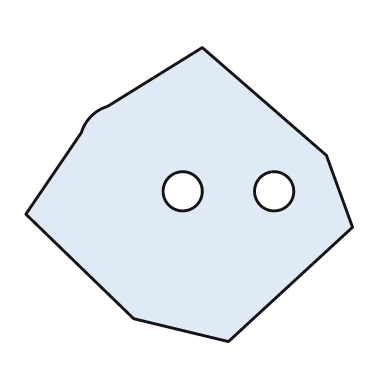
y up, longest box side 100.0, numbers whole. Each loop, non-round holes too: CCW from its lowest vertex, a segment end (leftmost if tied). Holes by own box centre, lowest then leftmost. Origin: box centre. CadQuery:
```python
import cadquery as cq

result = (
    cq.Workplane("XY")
    .moveTo(12.0, -45.0)
    .lineTo(50.0, -10.0)
    .lineTo(42.0, 12.0)
    .lineTo(4.0, 45.0)
    .lineTo(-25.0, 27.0)
    .threePointArc((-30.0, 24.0), (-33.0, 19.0))
    .lineTo(-50.0, -6.0)
    .lineTo(-17.0, -38.0)
    .close()
    .moveTo(-2.0, 1.0)
    .circle(6.0)
    .moveTo(26.0, 1.0)
    .circle(6.0)
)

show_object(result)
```